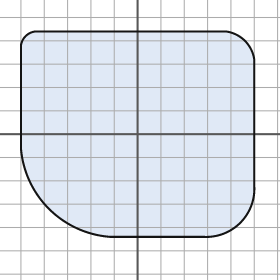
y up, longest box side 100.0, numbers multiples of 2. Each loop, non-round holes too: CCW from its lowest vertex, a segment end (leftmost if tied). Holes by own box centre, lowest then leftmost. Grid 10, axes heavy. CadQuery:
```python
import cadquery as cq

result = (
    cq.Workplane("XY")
    .moveTo(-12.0, -44.0)
    .lineTo(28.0, -44.0)
    .threePointArc((44.0, -38.0), (50.0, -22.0))
    .lineTo(50.0, 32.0)
    .threePointArc((46.0, 40.0), (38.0, 44.0))
    .lineTo(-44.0, 44.0)
    .threePointArc((-48.0, 42.0), (-50.0, 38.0))
    .lineTo(-50.0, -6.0)
    .threePointArc((-38.0, -32.0), (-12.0, -44.0))
    .close()
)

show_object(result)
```